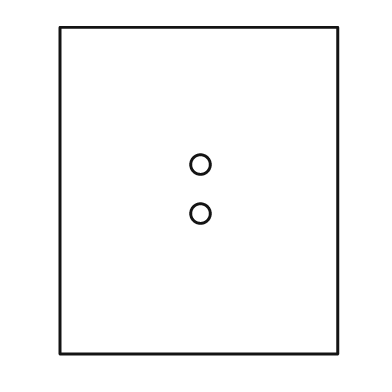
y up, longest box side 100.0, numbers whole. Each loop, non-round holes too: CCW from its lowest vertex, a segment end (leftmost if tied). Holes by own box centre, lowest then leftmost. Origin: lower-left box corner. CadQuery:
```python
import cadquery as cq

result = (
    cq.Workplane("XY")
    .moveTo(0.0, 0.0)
    .lineTo(85.0, 0.0)
    .lineTo(85.0, 100.0)
    .lineTo(0.0, 100.0)
    .close()
    .moveTo(43.0, 43.0)
    .circle(3.0)
    .moveTo(43.0, 58.0)
    .circle(3.0)
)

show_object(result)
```